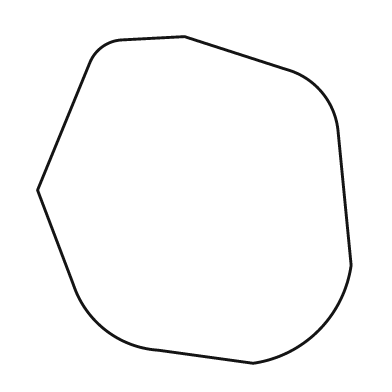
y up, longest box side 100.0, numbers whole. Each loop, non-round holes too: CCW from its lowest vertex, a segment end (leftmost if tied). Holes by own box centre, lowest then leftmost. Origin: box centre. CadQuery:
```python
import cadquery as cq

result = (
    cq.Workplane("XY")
    .moveTo(18.0, -50.0)
    .threePointArc((38.0, -40.0), (48.0, -20.0))
    .lineTo(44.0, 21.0)
    .threePointArc((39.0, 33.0), (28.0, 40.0))
    .lineTo(-3.0, 50.0)
    .lineTo(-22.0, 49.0)
    .threePointArc((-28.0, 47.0), (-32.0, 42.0))
    .lineTo(-48.0, 3.0)
    .lineTo(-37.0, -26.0)
    .threePointArc((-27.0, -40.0), (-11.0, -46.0))
    .close()
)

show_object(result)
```